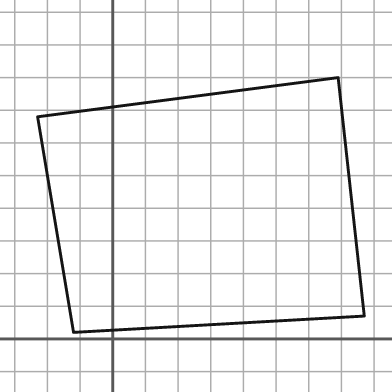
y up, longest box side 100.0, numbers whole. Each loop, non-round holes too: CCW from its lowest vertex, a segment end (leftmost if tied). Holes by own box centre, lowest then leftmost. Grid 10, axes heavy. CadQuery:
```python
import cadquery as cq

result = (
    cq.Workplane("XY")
    .moveTo(-12.0, 2.0)
    .lineTo(77.0, 7.0)
    .lineTo(69.0, 80.0)
    .lineTo(-23.0, 68.0)
    .close()
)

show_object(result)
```